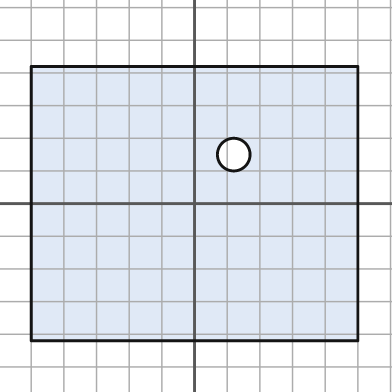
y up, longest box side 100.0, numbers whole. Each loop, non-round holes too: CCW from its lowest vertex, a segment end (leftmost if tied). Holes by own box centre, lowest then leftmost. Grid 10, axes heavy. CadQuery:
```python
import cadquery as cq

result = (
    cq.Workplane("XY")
    .moveTo(-50.0, -42.0)
    .lineTo(50.0, -42.0)
    .lineTo(50.0, 42.0)
    .lineTo(-50.0, 42.0)
    .close()
    .moveTo(12.0, 15.0)
    .circle(5.0)
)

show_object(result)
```